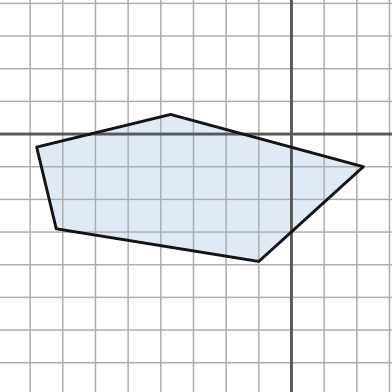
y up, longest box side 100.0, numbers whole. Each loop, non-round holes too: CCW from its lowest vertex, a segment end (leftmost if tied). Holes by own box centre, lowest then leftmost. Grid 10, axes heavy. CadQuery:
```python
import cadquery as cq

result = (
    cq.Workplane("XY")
    .moveTo(-10.0, -39.0)
    .lineTo(22.0, -10.0)
    .lineTo(-37.0, 6.0)
    .lineTo(-78.0, -4.0)
    .lineTo(-72.0, -29.0)
    .close()
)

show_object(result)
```